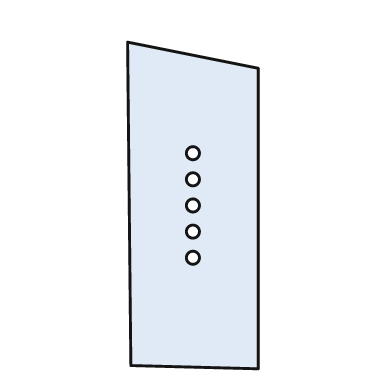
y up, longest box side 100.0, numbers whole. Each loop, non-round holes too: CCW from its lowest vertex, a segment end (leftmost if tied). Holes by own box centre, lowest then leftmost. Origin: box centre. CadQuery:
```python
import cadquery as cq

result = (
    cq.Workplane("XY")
    .moveTo(20.0, -50.0)
    .lineTo(20.0, 42.0)
    .lineTo(-20.0, 50.0)
    .lineTo(-19.0, -49.0)
    .close()
    .moveTo(0.0, -16.0)
    .circle(2.0)
    .moveTo(0.0, -8.0)
    .circle(2.0)
    .moveTo(0.0, 0.0)
    .circle(2.0)
    .moveTo(0.0, 8.0)
    .circle(2.0)
    .moveTo(0.0, 16.0)
    .circle(2.0)
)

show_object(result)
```